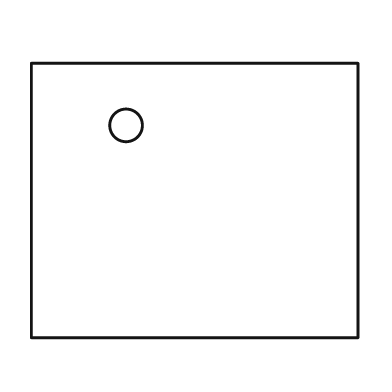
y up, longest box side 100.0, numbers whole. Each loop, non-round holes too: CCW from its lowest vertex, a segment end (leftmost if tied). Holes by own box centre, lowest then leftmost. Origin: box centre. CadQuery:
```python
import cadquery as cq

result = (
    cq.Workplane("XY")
    .moveTo(-50.0, -42.0)
    .lineTo(50.0, -42.0)
    .lineTo(50.0, 42.0)
    .lineTo(-50.0, 42.0)
    .close()
    .moveTo(-21.0, 23.0)
    .circle(5.0)
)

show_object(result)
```